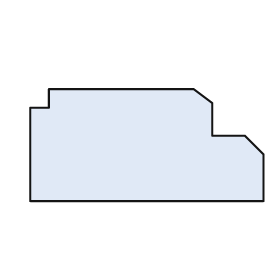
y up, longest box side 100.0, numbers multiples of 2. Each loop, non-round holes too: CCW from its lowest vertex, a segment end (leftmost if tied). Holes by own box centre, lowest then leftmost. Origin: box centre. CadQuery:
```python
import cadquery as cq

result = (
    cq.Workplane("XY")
    .moveTo(-50.0, -24.0)
    .lineTo(50.0, -24.0)
    .lineTo(50.0, -4.0)
    .lineTo(42.0, 4.0)
    .lineTo(28.0, 4.0)
    .lineTo(28.0, 18.0)
    .lineTo(20.0, 24.0)
    .lineTo(-42.0, 24.0)
    .lineTo(-42.0, 16.0)
    .lineTo(-50.0, 16.0)
    .close()
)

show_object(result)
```